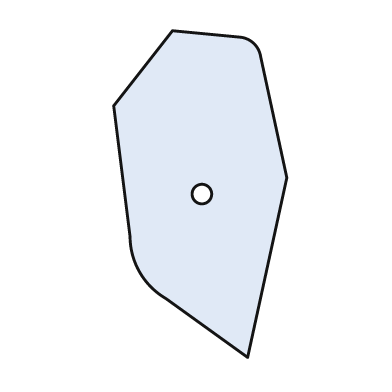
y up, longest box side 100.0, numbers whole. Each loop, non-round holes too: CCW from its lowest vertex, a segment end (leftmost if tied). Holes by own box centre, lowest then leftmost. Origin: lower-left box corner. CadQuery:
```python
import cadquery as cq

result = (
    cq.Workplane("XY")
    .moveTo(41.0, 0.0)
    .lineTo(53.0, 55.0)
    .lineTo(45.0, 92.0)
    .threePointArc((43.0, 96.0), (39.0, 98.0))
    .lineTo(18.0, 100.0)
    .lineTo(0.0, 77.0)
    .lineTo(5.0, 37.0)
    .threePointArc((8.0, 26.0), (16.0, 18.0))
    .close()
    .moveTo(27.0, 50.0)
    .circle(3.0)
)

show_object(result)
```